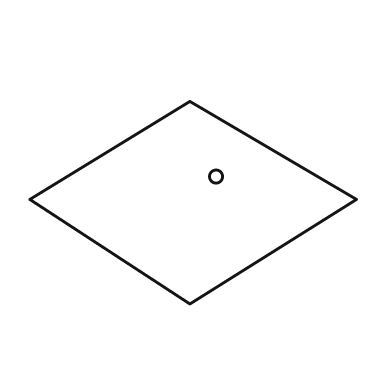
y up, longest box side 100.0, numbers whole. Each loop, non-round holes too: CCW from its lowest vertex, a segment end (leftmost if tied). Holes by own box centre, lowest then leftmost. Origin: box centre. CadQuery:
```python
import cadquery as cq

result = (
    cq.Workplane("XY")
    .moveTo(-1.0, -31.0)
    .lineTo(50.0, 1.0)
    .lineTo(-1.0, 31.0)
    .lineTo(-50.0, 1.0)
    .close()
    .moveTo(7.0, 8.0)
    .circle(2.0)
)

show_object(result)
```